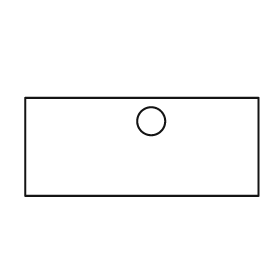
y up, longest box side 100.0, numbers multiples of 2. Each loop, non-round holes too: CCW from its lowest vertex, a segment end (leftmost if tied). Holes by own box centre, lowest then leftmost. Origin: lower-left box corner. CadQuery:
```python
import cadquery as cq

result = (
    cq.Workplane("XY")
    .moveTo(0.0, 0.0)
    .lineTo(100.0, 0.0)
    .lineTo(100.0, 42.0)
    .lineTo(0.0, 42.0)
    .close()
    .moveTo(54.0, 32.0)
    .circle(6.0)
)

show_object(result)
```